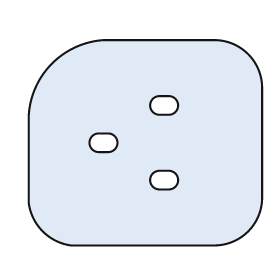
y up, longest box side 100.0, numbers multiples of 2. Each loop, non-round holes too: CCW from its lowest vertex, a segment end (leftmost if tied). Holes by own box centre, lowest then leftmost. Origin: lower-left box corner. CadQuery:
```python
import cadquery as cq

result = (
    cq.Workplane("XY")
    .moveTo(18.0, 0.0)
    .lineTo(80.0, 0.0)
    .threePointArc((94.0, 6.0), (100.0, 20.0))
    .lineTo(100.0, 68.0)
    .threePointArc((94.0, 82.0), (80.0, 88.0))
    .lineTo(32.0, 88.0)
    .threePointArc((10.0, 78.0), (0.0, 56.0))
    .lineTo(0.0, 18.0)
    .threePointArc((6.0, 6.0), (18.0, 0.0))
    .close()
    .moveTo(56.0, 24.0)
    .lineTo(60.0, 24.0)
    .threePointArc((64.0, 28.0), (60.0, 32.0))
    .lineTo(56.0, 32.0)
    .threePointArc((52.0, 28.0), (56.0, 24.0))
    .close()
    .moveTo(30.0, 40.0)
    .lineTo(34.0, 40.0)
    .threePointArc((38.0, 44.0), (34.0, 48.0))
    .lineTo(30.0, 48.0)
    .threePointArc((26.0, 44.0), (30.0, 40.0))
    .close()
    .moveTo(56.0, 56.0)
    .lineTo(60.0, 56.0)
    .threePointArc((64.0, 60.0), (60.0, 64.0))
    .lineTo(56.0, 64.0)
    .threePointArc((52.0, 60.0), (56.0, 56.0))
    .close()
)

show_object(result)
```